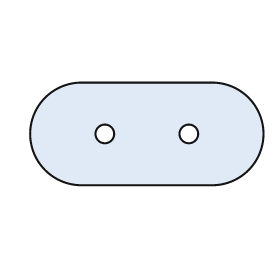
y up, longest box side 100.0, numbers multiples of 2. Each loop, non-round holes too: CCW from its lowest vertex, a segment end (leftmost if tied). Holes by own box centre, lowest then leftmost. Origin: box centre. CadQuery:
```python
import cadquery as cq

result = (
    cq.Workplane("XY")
    .moveTo(-28.0, -22.0)
    .lineTo(28.0, -22.0)
    .threePointArc((50.0, 0.0), (28.0, 22.0))
    .lineTo(-28.0, 22.0)
    .threePointArc((-50.0, 0.0), (-28.0, -22.0))
    .close()
    .moveTo(-18.0, 0.0)
    .circle(4.0)
    .moveTo(18.0, 0.0)
    .circle(4.0)
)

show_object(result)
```